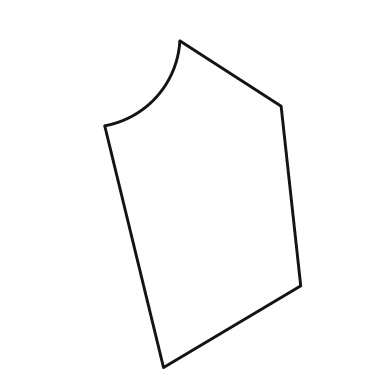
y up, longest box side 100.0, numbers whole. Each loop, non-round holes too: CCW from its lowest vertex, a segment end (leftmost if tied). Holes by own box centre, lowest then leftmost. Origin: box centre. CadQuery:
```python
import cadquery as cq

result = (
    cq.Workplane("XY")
    .moveTo(-12.0, -50.0)
    .lineTo(30.0, -25.0)
    .lineTo(24.0, 30.0)
    .lineTo(-7.0, 50.0)
    .threePointArc((-14.0, 33.0), (-30.0, 24.0))
    .close()
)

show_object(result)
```